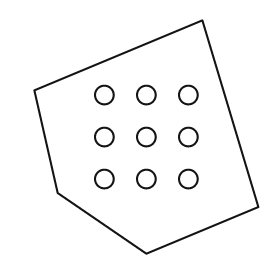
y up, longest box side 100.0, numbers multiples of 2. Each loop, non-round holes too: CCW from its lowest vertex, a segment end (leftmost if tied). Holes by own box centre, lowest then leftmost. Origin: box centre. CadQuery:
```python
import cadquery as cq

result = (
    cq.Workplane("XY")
    .moveTo(0.0, -50.0)
    .lineTo(48.0, -30.0)
    .lineTo(24.0, 50.0)
    .lineTo(-48.0, 20.0)
    .lineTo(-38.0, -24.0)
    .close()
    .moveTo(-18.0, -18.0)
    .circle(4.0)
    .moveTo(0.0, -18.0)
    .circle(4.0)
    .moveTo(18.0, -18.0)
    .circle(4.0)
    .moveTo(-18.0, 0.0)
    .circle(4.0)
    .moveTo(0.0, 0.0)
    .circle(4.0)
    .moveTo(18.0, 0.0)
    .circle(4.0)
    .moveTo(-18.0, 18.0)
    .circle(4.0)
    .moveTo(0.0, 18.0)
    .circle(4.0)
    .moveTo(18.0, 18.0)
    .circle(4.0)
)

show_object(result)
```